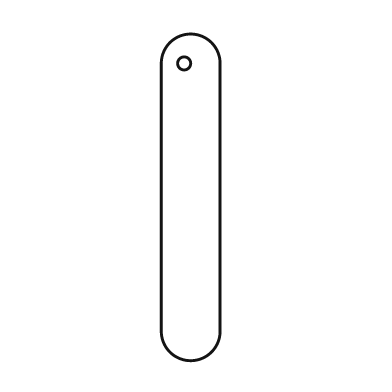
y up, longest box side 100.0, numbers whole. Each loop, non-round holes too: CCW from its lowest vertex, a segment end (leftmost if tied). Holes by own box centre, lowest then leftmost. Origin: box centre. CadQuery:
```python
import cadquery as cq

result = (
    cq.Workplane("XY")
    .moveTo(-9.0, -41.0)
    .threePointArc((0.0, -50.0), (9.0, -41.0))
    .lineTo(9.0, 41.0)
    .threePointArc((0.0, 50.0), (-9.0, 41.0))
    .close()
    .moveTo(-2.0, 41.0)
    .circle(2.0)
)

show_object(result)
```